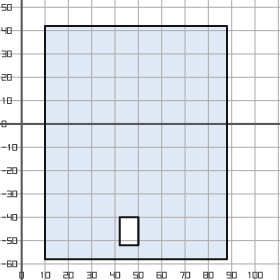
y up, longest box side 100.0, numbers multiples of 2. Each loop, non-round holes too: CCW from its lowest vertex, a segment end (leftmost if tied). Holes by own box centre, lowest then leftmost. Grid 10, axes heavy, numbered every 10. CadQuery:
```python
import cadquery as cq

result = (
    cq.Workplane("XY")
    .moveTo(10.0, -58.0)
    .lineTo(88.0, -58.0)
    .lineTo(88.0, 42.0)
    .lineTo(10.0, 42.0)
    .close()
    .moveTo(42.0, -52.0)
    .lineTo(50.0, -52.0)
    .lineTo(50.0, -40.0)
    .lineTo(42.0, -40.0)
    .close()
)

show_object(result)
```